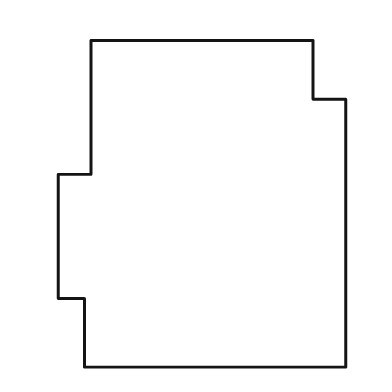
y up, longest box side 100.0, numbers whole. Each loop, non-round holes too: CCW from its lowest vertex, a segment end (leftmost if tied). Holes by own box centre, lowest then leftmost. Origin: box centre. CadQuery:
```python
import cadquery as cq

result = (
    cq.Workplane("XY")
    .moveTo(-36.0, -50.0)
    .lineTo(44.0, -50.0)
    .lineTo(44.0, 32.0)
    .lineTo(34.0, 32.0)
    .lineTo(34.0, 50.0)
    .lineTo(-34.0, 50.0)
    .lineTo(-34.0, 9.0)
    .lineTo(-44.0, 9.0)
    .lineTo(-44.0, -29.0)
    .lineTo(-36.0, -29.0)
    .close()
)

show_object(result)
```